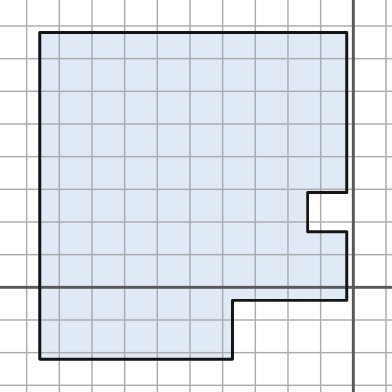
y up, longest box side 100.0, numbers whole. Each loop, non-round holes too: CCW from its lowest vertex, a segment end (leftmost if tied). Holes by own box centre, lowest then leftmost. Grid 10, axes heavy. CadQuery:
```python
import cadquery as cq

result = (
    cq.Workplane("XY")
    .moveTo(-96.0, -22.0)
    .lineTo(-37.0, -22.0)
    .lineTo(-37.0, -4.0)
    .lineTo(-2.0, -4.0)
    .lineTo(-2.0, 17.0)
    .lineTo(-14.0, 17.0)
    .lineTo(-14.0, 29.0)
    .lineTo(-2.0, 29.0)
    .lineTo(-2.0, 78.0)
    .lineTo(-96.0, 78.0)
    .close()
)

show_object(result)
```